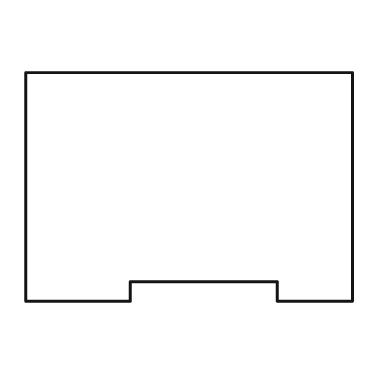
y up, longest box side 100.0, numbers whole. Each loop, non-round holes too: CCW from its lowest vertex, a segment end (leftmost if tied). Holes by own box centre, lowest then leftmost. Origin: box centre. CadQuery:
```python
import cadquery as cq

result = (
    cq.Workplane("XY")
    .moveTo(-50.0, -35.0)
    .lineTo(-18.0, -35.0)
    .lineTo(-18.0, -29.0)
    .lineTo(27.0, -29.0)
    .lineTo(27.0, -35.0)
    .lineTo(50.0, -35.0)
    .lineTo(50.0, 35.0)
    .lineTo(-50.0, 35.0)
    .close()
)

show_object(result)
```